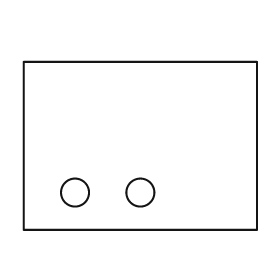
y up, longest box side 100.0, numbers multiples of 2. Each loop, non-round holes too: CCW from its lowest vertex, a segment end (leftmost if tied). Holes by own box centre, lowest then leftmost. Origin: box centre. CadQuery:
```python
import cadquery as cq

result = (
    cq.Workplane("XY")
    .moveTo(-50.0, -36.0)
    .lineTo(50.0, -36.0)
    .lineTo(50.0, 36.0)
    .lineTo(-50.0, 36.0)
    .close()
    .moveTo(-28.0, -20.0)
    .circle(6.0)
    .moveTo(0.0, -20.0)
    .circle(6.0)
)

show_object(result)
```